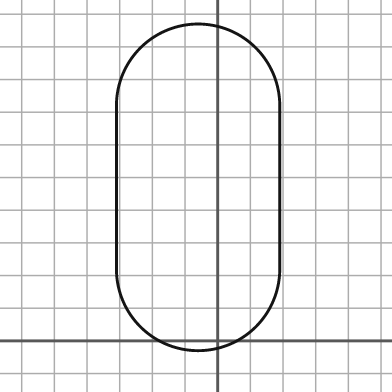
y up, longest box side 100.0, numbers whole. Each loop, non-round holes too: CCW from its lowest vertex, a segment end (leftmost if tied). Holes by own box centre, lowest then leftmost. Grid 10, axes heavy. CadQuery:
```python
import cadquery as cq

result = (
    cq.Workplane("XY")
    .moveTo(-31.0, 22.0)
    .threePointArc((-6.0, -3.0), (19.0, 22.0))
    .lineTo(19.0, 72.0)
    .threePointArc((-6.0, 97.0), (-31.0, 72.0))
    .close()
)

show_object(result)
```